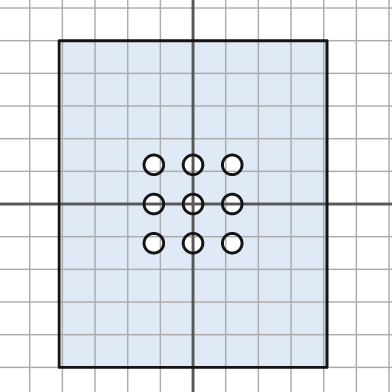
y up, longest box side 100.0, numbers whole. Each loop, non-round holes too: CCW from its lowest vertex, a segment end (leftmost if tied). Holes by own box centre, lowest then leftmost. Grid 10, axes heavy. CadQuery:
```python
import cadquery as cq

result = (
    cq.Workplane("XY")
    .moveTo(-41.0, -50.0)
    .lineTo(41.0, -50.0)
    .lineTo(41.0, 50.0)
    .lineTo(-41.0, 50.0)
    .close()
    .moveTo(-12.0, -12.0)
    .circle(3.0)
    .moveTo(0.0, -12.0)
    .circle(3.0)
    .moveTo(12.0, -12.0)
    .circle(3.0)
    .moveTo(-12.0, 0.0)
    .circle(3.0)
    .moveTo(0.0, 0.0)
    .circle(3.0)
    .moveTo(12.0, 0.0)
    .circle(3.0)
    .moveTo(-12.0, 12.0)
    .circle(3.0)
    .moveTo(0.0, 12.0)
    .circle(3.0)
    .moveTo(12.0, 12.0)
    .circle(3.0)
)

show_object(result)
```